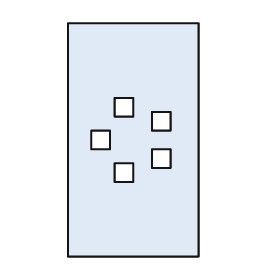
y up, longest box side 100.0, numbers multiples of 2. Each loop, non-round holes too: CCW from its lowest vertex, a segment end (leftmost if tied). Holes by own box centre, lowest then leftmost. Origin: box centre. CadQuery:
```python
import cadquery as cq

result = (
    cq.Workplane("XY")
    .moveTo(-28.0, -50.0)
    .lineTo(28.0, -50.0)
    .lineTo(28.0, 50.0)
    .lineTo(-28.0, 50.0)
    .close()
    .moveTo(-8.0, -18.0)
    .lineTo(0.0, -18.0)
    .lineTo(0.0, -10.0)
    .lineTo(-8.0, -10.0)
    .close()
    .moveTo(8.0, -12.0)
    .lineTo(16.0, -12.0)
    .lineTo(16.0, -4.0)
    .lineTo(8.0, -4.0)
    .close()
    .moveTo(-18.0, -4.0)
    .lineTo(-10.0, -4.0)
    .lineTo(-10.0, 4.0)
    .lineTo(-18.0, 4.0)
    .close()
    .moveTo(8.0, 4.0)
    .lineTo(16.0, 4.0)
    .lineTo(16.0, 12.0)
    .lineTo(8.0, 12.0)
    .close()
    .moveTo(-8.0, 10.0)
    .lineTo(0.0, 10.0)
    .lineTo(0.0, 18.0)
    .lineTo(-8.0, 18.0)
    .close()
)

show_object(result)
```